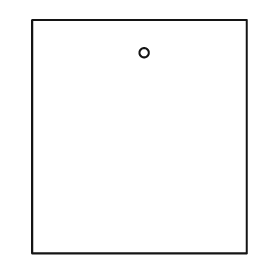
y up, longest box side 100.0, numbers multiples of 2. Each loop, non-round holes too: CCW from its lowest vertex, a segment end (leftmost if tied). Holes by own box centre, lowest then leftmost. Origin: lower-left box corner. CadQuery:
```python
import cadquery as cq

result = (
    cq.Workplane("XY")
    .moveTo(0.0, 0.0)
    .lineTo(92.0, 0.0)
    .lineTo(92.0, 100.0)
    .lineTo(0.0, 100.0)
    .close()
    .moveTo(48.0, 86.0)
    .circle(2.0)
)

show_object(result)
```